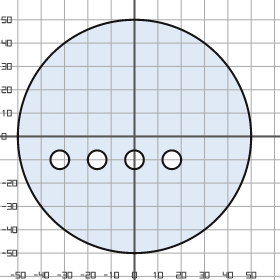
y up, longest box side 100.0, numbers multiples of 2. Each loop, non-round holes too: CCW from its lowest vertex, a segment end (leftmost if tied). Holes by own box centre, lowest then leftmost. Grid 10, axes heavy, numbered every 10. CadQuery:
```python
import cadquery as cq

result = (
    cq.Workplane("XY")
    .moveTo(0.0, 0.0)
    .circle(50.0)
    .moveTo(-32.0, -10.0)
    .circle(4.0)
    .moveTo(-16.0, -10.0)
    .circle(4.0)
    .moveTo(0.0, -10.0)
    .circle(4.0)
    .moveTo(16.0, -10.0)
    .circle(4.0)
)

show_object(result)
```